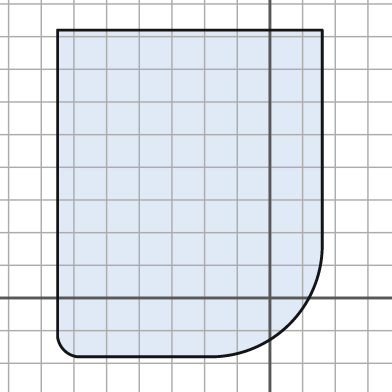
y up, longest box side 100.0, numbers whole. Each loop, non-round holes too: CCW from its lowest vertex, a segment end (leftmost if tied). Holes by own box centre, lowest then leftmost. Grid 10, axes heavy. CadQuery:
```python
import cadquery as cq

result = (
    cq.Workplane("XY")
    .moveTo(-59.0, -18.0)
    .lineTo(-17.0, -18.0)
    .threePointArc((6.0, -8.0), (16.0, 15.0))
    .lineTo(16.0, 82.0)
    .lineTo(-65.0, 82.0)
    .lineTo(-65.0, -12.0)
    .threePointArc((-63.0, -16.0), (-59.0, -18.0))
    .close()
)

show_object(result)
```